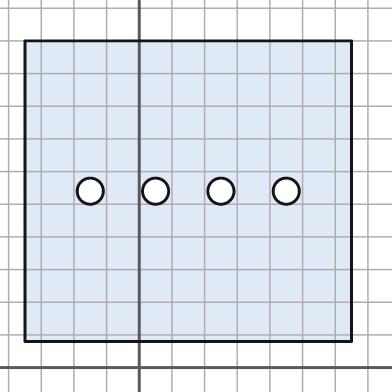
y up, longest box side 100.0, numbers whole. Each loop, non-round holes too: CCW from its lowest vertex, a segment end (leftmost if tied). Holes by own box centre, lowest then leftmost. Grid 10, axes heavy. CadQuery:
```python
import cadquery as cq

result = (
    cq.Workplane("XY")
    .moveTo(-35.0, 8.0)
    .lineTo(65.0, 8.0)
    .lineTo(65.0, 100.0)
    .lineTo(-35.0, 100.0)
    .close()
    .moveTo(-15.0, 54.0)
    .circle(4.0)
    .moveTo(5.0, 54.0)
    .circle(4.0)
    .moveTo(25.0, 54.0)
    .circle(4.0)
    .moveTo(45.0, 54.0)
    .circle(4.0)
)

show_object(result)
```